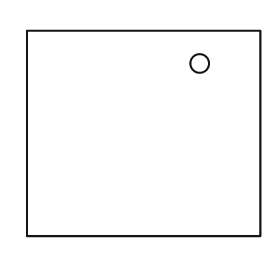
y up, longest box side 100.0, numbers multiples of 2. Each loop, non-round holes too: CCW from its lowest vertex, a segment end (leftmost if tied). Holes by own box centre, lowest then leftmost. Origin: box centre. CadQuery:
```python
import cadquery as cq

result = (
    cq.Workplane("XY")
    .moveTo(-50.0, -44.0)
    .lineTo(50.0, -44.0)
    .lineTo(50.0, 44.0)
    .lineTo(-50.0, 44.0)
    .close()
    .moveTo(24.0, 30.0)
    .circle(4.0)
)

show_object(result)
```